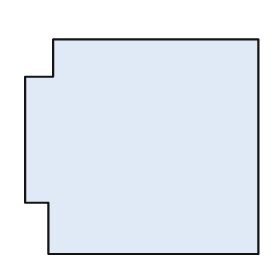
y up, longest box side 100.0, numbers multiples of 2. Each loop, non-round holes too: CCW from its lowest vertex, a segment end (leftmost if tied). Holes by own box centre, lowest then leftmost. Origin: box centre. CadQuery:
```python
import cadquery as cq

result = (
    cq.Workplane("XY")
    .moveTo(-40.0, -46.0)
    .lineTo(50.0, -46.0)
    .lineTo(50.0, 46.0)
    .lineTo(-38.0, 46.0)
    .lineTo(-38.0, 30.0)
    .lineTo(-50.0, 30.0)
    .lineTo(-50.0, -24.0)
    .lineTo(-40.0, -24.0)
    .close()
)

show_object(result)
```